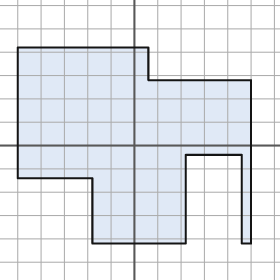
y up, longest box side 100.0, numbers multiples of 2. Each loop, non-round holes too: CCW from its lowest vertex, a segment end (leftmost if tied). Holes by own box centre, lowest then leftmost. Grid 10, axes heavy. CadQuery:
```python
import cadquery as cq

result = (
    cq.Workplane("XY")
    .moveTo(-18.0, -42.0)
    .lineTo(22.0, -42.0)
    .lineTo(22.0, -4.0)
    .lineTo(46.0, -4.0)
    .lineTo(46.0, -42.0)
    .lineTo(50.0, -42.0)
    .lineTo(50.0, 28.0)
    .lineTo(6.0, 28.0)
    .lineTo(6.0, 42.0)
    .lineTo(-50.0, 42.0)
    .lineTo(-50.0, -14.0)
    .lineTo(-18.0, -14.0)
    .close()
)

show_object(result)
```